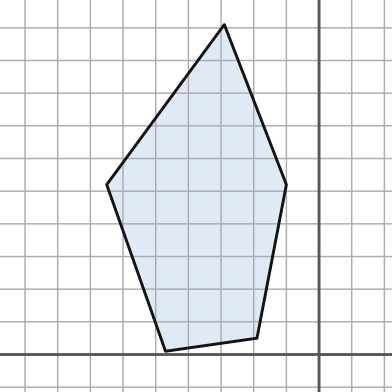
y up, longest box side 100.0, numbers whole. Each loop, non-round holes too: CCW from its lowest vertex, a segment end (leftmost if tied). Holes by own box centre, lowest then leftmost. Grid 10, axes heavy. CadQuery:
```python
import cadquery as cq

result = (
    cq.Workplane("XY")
    .moveTo(-47.0, 1.0)
    .lineTo(-19.0, 5.0)
    .lineTo(-10.0, 52.0)
    .lineTo(-29.0, 101.0)
    .lineTo(-65.0, 52.0)
    .close()
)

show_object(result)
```